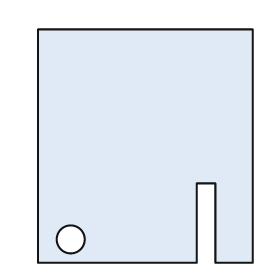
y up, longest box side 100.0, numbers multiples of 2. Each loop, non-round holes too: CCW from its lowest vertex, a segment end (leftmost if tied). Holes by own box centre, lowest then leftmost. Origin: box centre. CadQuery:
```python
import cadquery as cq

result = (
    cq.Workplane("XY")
    .moveTo(-46.0, -50.0)
    .lineTo(22.0, -50.0)
    .lineTo(22.0, -16.0)
    .lineTo(30.0, -16.0)
    .lineTo(30.0, -50.0)
    .lineTo(46.0, -50.0)
    .lineTo(46.0, 50.0)
    .lineTo(-46.0, 50.0)
    .close()
    .moveTo(-32.0, -40.0)
    .circle(6.0)
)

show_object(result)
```